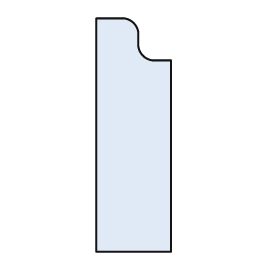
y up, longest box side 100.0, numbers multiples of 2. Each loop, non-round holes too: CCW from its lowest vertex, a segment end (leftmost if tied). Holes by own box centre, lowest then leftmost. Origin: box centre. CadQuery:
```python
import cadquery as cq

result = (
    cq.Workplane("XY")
    .moveTo(-16.0, -50.0)
    .lineTo(16.0, -50.0)
    .lineTo(16.0, 32.0)
    .lineTo(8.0, 32.0)
    .threePointArc((4.0, 34.0), (2.0, 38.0))
    .lineTo(2.0, 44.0)
    .threePointArc((0.0, 48.0), (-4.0, 50.0))
    .lineTo(-16.0, 50.0)
    .close()
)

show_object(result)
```